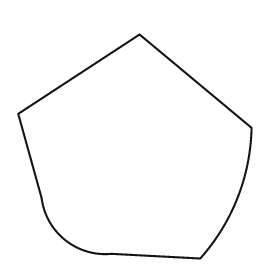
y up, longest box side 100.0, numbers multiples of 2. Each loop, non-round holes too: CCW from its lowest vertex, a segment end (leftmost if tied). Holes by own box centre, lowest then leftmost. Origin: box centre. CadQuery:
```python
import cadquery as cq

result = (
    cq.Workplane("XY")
    .moveTo(28.0, -48.0)
    .threePointArc((44.0, -22.0), (50.0, 8.0))
    .lineTo(2.0, 48.0)
    .lineTo(-50.0, 14.0)
    .lineTo(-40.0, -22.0)
    .threePointArc((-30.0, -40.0), (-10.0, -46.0))
    .close()
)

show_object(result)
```